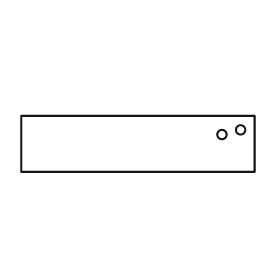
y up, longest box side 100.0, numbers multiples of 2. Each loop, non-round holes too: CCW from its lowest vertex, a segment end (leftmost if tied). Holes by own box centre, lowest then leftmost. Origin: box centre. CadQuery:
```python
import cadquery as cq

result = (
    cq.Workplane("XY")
    .moveTo(-50.0, -12.0)
    .lineTo(50.0, -12.0)
    .lineTo(50.0, 12.0)
    .lineTo(-50.0, 12.0)
    .close()
    .moveTo(36.0, 4.0)
    .circle(2.0)
    .moveTo(44.0, 6.0)
    .circle(2.0)
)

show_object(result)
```